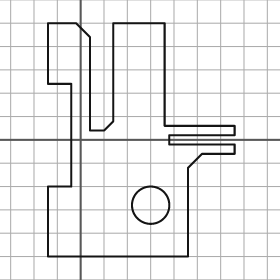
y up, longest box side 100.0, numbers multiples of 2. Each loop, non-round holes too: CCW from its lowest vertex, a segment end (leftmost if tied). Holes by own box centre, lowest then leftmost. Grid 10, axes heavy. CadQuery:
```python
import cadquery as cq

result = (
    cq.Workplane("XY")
    .moveTo(-14.0, -50.0)
    .lineTo(46.0, -50.0)
    .lineTo(46.0, -12.0)
    .lineTo(52.0, -6.0)
    .lineTo(66.0, -6.0)
    .lineTo(66.0, -2.0)
    .lineTo(38.0, -2.0)
    .lineTo(38.0, 2.0)
    .lineTo(66.0, 2.0)
    .lineTo(66.0, 6.0)
    .lineTo(36.0, 6.0)
    .lineTo(36.0, 50.0)
    .lineTo(14.0, 50.0)
    .lineTo(14.0, 8.0)
    .lineTo(10.0, 4.0)
    .lineTo(4.0, 4.0)
    .lineTo(4.0, 44.0)
    .lineTo(-2.0, 50.0)
    .lineTo(-14.0, 50.0)
    .lineTo(-14.0, 24.0)
    .lineTo(-4.0, 24.0)
    .lineTo(-4.0, -20.0)
    .lineTo(-14.0, -20.0)
    .close()
    .moveTo(30.0, -28.0)
    .circle(8.0)
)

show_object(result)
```